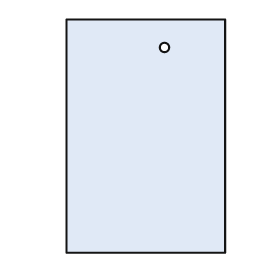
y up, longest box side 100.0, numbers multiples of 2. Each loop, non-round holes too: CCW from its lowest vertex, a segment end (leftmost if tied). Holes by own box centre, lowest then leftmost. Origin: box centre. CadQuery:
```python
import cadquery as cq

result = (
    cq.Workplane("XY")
    .moveTo(-34.0, -50.0)
    .lineTo(34.0, -50.0)
    .lineTo(34.0, 50.0)
    .lineTo(-34.0, 50.0)
    .close()
    .moveTo(8.0, 38.0)
    .circle(2.0)
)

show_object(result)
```